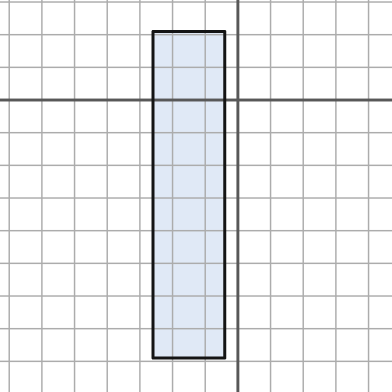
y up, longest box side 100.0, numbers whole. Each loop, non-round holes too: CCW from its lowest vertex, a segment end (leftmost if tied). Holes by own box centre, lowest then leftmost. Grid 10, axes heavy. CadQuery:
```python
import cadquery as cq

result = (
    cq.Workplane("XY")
    .moveTo(-26.0, -79.0)
    .lineTo(-4.0, -79.0)
    .lineTo(-4.0, 21.0)
    .lineTo(-26.0, 21.0)
    .close()
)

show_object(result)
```